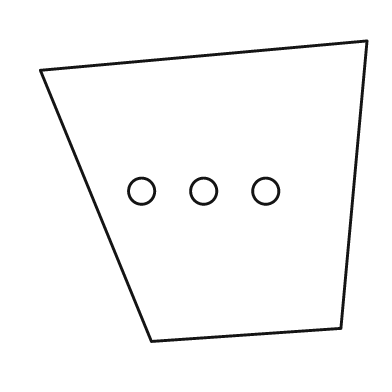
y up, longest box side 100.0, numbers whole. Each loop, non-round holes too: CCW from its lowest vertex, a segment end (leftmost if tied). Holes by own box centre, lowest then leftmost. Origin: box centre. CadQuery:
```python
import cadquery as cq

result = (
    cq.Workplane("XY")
    .moveTo(-16.0, -46.0)
    .lineTo(42.0, -42.0)
    .lineTo(50.0, 46.0)
    .lineTo(-50.0, 37.0)
    .close()
    .moveTo(-19.0, 0.0)
    .circle(4.0)
    .moveTo(0.0, 0.0)
    .circle(4.0)
    .moveTo(19.0, 0.0)
    .circle(4.0)
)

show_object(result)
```